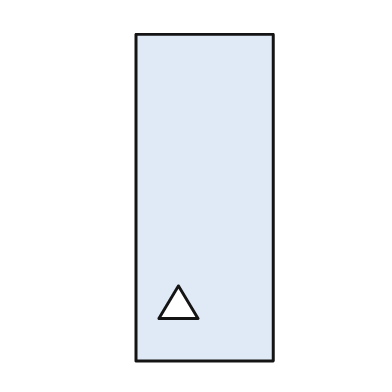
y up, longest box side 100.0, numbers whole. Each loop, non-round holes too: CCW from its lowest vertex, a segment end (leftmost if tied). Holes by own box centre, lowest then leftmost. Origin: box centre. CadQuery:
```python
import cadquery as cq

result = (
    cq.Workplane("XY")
    .moveTo(-21.0, -50.0)
    .lineTo(21.0, -50.0)
    .lineTo(21.0, 50.0)
    .lineTo(-21.0, 50.0)
    .close()
    .moveTo(-14.0, -37.0)
    .lineTo(-2.0, -37.0)
    .lineTo(-8.0, -27.0)
    .close()
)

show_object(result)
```